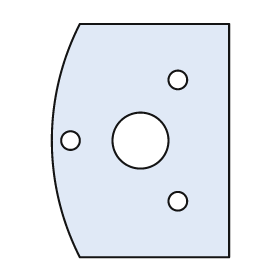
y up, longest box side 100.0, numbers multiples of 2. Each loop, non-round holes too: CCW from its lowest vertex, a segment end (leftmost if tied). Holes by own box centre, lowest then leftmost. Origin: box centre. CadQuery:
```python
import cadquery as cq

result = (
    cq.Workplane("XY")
    .moveTo(-26.0, -50.0)
    .lineTo(38.0, -50.0)
    .lineTo(38.0, 50.0)
    .lineTo(-26.0, 50.0)
    .threePointArc((-38.0, 0.0), (-26.0, -50.0))
    .close()
    .moveTo(16.0, -26.0)
    .circle(4.0)
    .moveTo(-30.0, 0.0)
    .circle(4.0)
    .moveTo(0.0, 0.0)
    .circle(12.0)
    .moveTo(16.0, 26.0)
    .circle(4.0)
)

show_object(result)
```